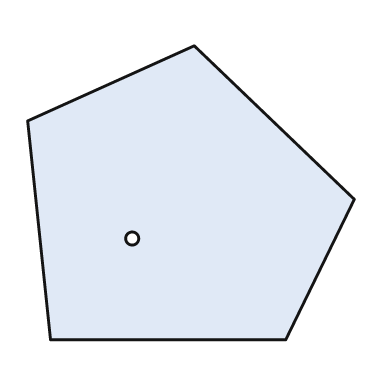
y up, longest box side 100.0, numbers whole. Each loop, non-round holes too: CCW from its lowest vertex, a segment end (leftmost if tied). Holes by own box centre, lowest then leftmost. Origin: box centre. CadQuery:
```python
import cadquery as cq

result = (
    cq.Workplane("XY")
    .moveTo(-43.0, -45.0)
    .lineTo(29.0, -45.0)
    .lineTo(50.0, -2.0)
    .lineTo(1.0, 45.0)
    .lineTo(-50.0, 22.0)
    .close()
    .moveTo(-18.0, -14.0)
    .circle(2.0)
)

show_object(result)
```